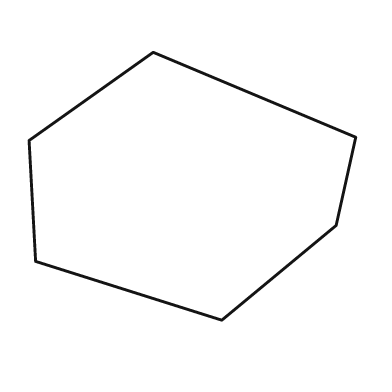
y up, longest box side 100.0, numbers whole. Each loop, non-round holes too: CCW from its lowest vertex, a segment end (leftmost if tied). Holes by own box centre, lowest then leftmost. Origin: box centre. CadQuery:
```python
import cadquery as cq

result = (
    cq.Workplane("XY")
    .moveTo(9.0, -41.0)
    .lineTo(44.0, -12.0)
    .lineTo(50.0, 15.0)
    .lineTo(-12.0, 41.0)
    .lineTo(-50.0, 14.0)
    .lineTo(-48.0, -23.0)
    .close()
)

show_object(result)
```